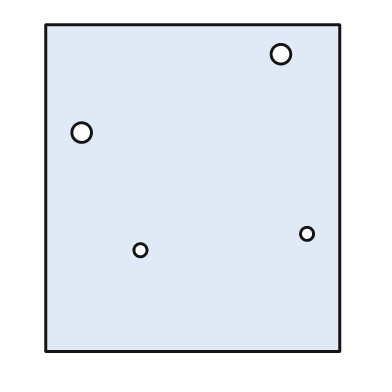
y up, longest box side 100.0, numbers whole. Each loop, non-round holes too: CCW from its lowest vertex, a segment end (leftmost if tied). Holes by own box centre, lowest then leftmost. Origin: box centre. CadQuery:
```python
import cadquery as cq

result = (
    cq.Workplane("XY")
    .moveTo(-45.0, -50.0)
    .lineTo(45.0, -50.0)
    .lineTo(45.0, 50.0)
    .lineTo(-45.0, 50.0)
    .close()
    .moveTo(-16.0, -19.0)
    .circle(2.0)
    .moveTo(35.0, -14.0)
    .circle(2.0)
    .moveTo(-34.0, 17.0)
    .circle(3.0)
    .moveTo(27.0, 41.0)
    .circle(3.0)
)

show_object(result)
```